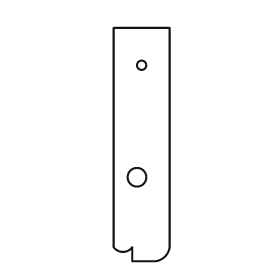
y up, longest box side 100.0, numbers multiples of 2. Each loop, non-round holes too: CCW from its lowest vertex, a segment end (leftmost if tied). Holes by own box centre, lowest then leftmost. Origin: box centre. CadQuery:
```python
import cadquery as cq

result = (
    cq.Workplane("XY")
    .moveTo(-4.0, -50.0)
    .lineTo(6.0, -50.0)
    .threePointArc((10.0, -48.0), (12.0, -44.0))
    .lineTo(12.0, 50.0)
    .lineTo(-12.0, 50.0)
    .lineTo(-12.0, -44.0)
    .threePointArc((-8.0, -46.0), (-4.0, -44.0))
    .close()
    .moveTo(-2.0, -14.0)
    .circle(4.0)
    .moveTo(0.0, 34.0)
    .circle(2.0)
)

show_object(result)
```